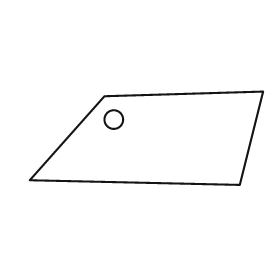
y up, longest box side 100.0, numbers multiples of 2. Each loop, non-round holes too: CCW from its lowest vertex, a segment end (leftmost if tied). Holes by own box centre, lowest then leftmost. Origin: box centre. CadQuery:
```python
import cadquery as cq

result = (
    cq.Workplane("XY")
    .moveTo(40.0, -20.0)
    .lineTo(50.0, 20.0)
    .lineTo(-18.0, 18.0)
    .lineTo(-50.0, -18.0)
    .close()
    .moveTo(-14.0, 8.0)
    .circle(4.0)
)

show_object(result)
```